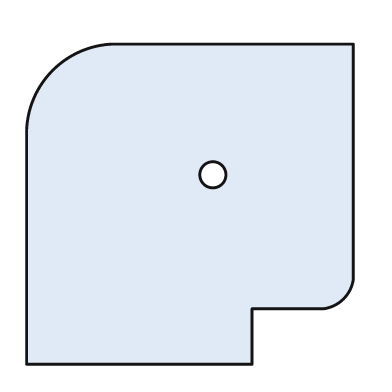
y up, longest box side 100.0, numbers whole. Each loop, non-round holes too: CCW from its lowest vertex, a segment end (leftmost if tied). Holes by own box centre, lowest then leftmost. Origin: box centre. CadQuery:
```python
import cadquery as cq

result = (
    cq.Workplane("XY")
    .moveTo(-50.0, -49.0)
    .lineTo(19.0, -49.0)
    .lineTo(19.0, -32.0)
    .lineTo(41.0, -32.0)
    .threePointArc((47.0, -29.0), (50.0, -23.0))
    .lineTo(50.0, 49.0)
    .lineTo(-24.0, 49.0)
    .threePointArc((-42.0, 41.0), (-50.0, 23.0))
    .close()
    .moveTo(7.0, 9.0)
    .circle(4.0)
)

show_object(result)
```